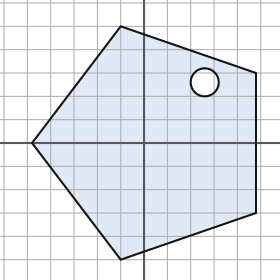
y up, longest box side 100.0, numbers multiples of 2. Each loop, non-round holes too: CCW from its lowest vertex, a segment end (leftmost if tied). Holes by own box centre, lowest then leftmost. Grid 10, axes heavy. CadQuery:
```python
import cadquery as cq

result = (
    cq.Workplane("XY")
    .moveTo(-10.0, -50.0)
    .lineTo(48.0, -30.0)
    .lineTo(48.0, 30.0)
    .lineTo(-10.0, 50.0)
    .lineTo(-48.0, 0.0)
    .close()
    .moveTo(26.0, 26.0)
    .circle(6.0)
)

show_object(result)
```